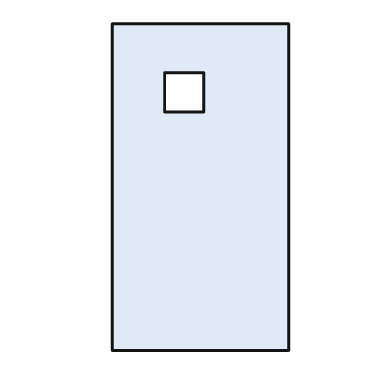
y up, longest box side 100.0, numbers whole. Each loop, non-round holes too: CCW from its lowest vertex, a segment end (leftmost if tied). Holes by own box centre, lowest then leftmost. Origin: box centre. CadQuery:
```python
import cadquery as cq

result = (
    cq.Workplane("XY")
    .moveTo(-27.0, -50.0)
    .lineTo(27.0, -50.0)
    .lineTo(27.0, 50.0)
    .lineTo(-27.0, 50.0)
    .close()
    .moveTo(-11.0, 23.0)
    .lineTo(1.0, 23.0)
    .lineTo(1.0, 35.0)
    .lineTo(-11.0, 35.0)
    .close()
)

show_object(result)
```